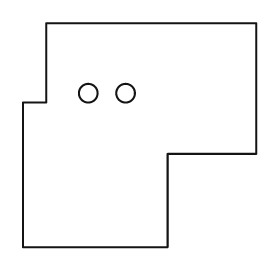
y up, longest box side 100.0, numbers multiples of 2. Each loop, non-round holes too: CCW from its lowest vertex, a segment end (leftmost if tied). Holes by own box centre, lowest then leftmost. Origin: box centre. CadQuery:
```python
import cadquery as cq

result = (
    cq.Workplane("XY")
    .moveTo(-50.0, -48.0)
    .lineTo(12.0, -48.0)
    .lineTo(12.0, -8.0)
    .lineTo(50.0, -8.0)
    .lineTo(50.0, 48.0)
    .lineTo(-40.0, 48.0)
    .lineTo(-40.0, 14.0)
    .lineTo(-50.0, 14.0)
    .close()
    .moveTo(-22.0, 18.0)
    .circle(4.0)
    .moveTo(-6.0, 18.0)
    .circle(4.0)
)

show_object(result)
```